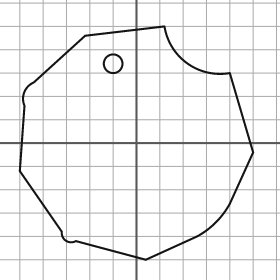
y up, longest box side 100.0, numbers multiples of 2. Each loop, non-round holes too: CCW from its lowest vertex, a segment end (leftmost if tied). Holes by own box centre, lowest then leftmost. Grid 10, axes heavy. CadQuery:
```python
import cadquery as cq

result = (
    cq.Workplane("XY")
    .moveTo(4.0, -50.0)
    .lineTo(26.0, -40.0)
    .threePointArc((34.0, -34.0), (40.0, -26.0))
    .lineTo(50.0, -4.0)
    .lineTo(40.0, 30.0)
    .threePointArc((22.0, 34.0), (12.0, 50.0))
    .lineTo(-22.0, 46.0)
    .lineTo(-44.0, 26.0)
    .threePointArc((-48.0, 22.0), (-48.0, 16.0))
    .lineTo(-50.0, -12.0)
    .lineTo(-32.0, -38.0)
    .threePointArc((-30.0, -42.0), (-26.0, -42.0))
    .close()
    .moveTo(-10.0, 34.0)
    .circle(4.0)
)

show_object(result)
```